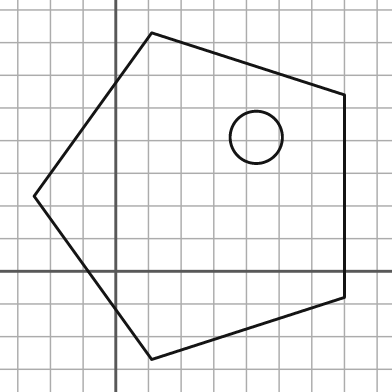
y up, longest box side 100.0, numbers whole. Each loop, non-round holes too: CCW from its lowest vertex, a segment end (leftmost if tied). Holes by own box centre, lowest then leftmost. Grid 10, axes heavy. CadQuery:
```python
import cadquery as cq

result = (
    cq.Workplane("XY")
    .moveTo(11.0, -27.0)
    .lineTo(70.0, -8.0)
    .lineTo(70.0, 54.0)
    .lineTo(11.0, 73.0)
    .lineTo(-25.0, 23.0)
    .close()
    .moveTo(43.0, 41.0)
    .circle(8.0)
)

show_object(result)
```